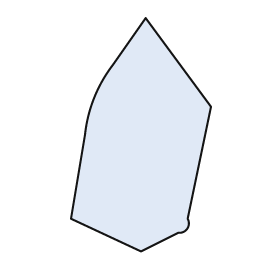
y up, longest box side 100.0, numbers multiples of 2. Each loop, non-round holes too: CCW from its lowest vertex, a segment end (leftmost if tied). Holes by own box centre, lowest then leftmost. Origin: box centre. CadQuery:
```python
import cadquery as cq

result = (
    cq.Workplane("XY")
    .moveTo(0.0, -50.0)
    .lineTo(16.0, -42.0)
    .threePointArc((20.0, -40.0), (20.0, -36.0))
    .lineTo(30.0, 12.0)
    .lineTo(2.0, 50.0)
    .lineTo(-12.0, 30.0)
    .threePointArc((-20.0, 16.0), (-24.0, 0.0))
    .lineTo(-30.0, -36.0)
    .close()
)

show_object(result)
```